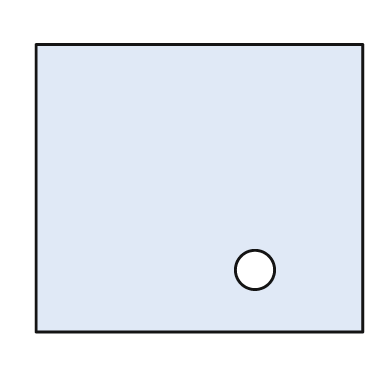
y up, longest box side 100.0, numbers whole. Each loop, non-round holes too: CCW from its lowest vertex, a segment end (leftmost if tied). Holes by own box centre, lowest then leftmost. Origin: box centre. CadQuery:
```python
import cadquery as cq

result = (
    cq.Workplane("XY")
    .moveTo(-50.0, -44.0)
    .lineTo(50.0, -44.0)
    .lineTo(50.0, 44.0)
    .lineTo(-50.0, 44.0)
    .close()
    .moveTo(17.0, -25.0)
    .circle(6.0)
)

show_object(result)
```